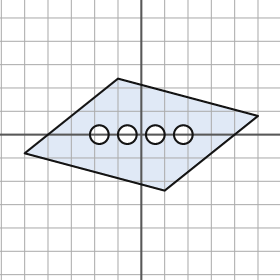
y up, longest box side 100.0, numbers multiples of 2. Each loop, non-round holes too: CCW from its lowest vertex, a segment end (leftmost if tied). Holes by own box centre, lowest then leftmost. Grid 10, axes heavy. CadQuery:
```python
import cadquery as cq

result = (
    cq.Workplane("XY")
    .moveTo(10.0, -24.0)
    .lineTo(50.0, 8.0)
    .lineTo(-10.0, 24.0)
    .lineTo(-50.0, -8.0)
    .close()
    .moveTo(-18.0, 0.0)
    .circle(4.0)
    .moveTo(-6.0, 0.0)
    .circle(4.0)
    .moveTo(6.0, 0.0)
    .circle(4.0)
    .moveTo(18.0, 0.0)
    .circle(4.0)
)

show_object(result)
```